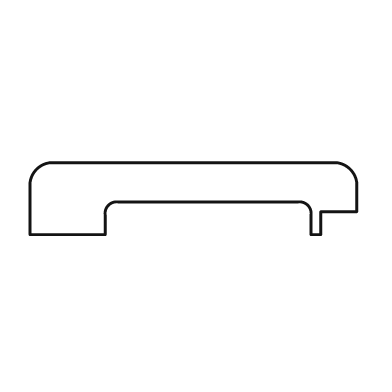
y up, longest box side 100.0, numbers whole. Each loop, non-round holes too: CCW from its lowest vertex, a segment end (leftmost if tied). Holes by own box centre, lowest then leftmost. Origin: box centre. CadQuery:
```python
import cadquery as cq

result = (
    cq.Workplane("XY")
    .moveTo(-50.0, -11.0)
    .lineTo(-27.0, -11.0)
    .lineTo(-27.0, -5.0)
    .threePointArc((-26.0, -2.0), (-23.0, -1.0))
    .lineTo(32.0, -1.0)
    .threePointArc((35.0, -2.0), (36.0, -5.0))
    .lineTo(36.0, -11.0)
    .lineTo(39.0, -11.0)
    .lineTo(39.0, -4.0)
    .lineTo(50.0, -4.0)
    .lineTo(50.0, 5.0)
    .threePointArc((48.0, 9.0), (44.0, 11.0))
    .lineTo(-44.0, 11.0)
    .threePointArc((-48.0, 9.0), (-50.0, 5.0))
    .close()
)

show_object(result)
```